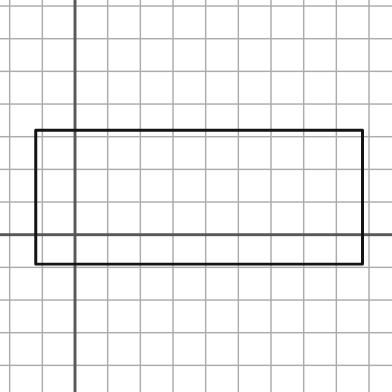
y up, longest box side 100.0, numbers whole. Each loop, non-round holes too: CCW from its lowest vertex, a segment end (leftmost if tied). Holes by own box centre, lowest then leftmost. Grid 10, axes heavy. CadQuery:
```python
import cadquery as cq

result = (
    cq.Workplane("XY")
    .moveTo(-12.0, -9.0)
    .lineTo(88.0, -9.0)
    .lineTo(88.0, 32.0)
    .lineTo(-12.0, 32.0)
    .close()
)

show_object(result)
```